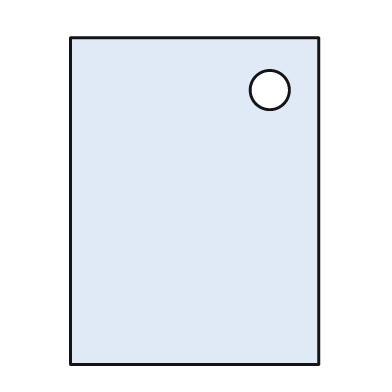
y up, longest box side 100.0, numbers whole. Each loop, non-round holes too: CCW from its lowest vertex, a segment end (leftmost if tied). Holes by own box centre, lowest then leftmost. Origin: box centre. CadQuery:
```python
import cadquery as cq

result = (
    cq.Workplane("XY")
    .moveTo(-38.0, -50.0)
    .lineTo(38.0, -50.0)
    .lineTo(38.0, 50.0)
    .lineTo(-38.0, 50.0)
    .close()
    .moveTo(23.0, 34.0)
    .circle(6.0)
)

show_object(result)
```